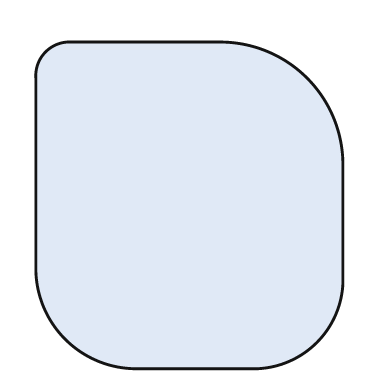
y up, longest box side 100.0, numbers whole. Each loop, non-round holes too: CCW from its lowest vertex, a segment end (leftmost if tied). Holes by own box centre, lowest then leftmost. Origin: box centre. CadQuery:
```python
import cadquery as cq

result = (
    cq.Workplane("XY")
    .moveTo(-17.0, -50.0)
    .lineTo(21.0, -50.0)
    .threePointArc((39.0, -42.0), (47.0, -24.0))
    .lineTo(47.0, 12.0)
    .threePointArc((36.0, 39.0), (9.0, 50.0))
    .lineTo(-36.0, 50.0)
    .threePointArc((-44.0, 47.0), (-47.0, 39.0))
    .lineTo(-47.0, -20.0)
    .threePointArc((-38.0, -41.0), (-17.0, -50.0))
    .close()
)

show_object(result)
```